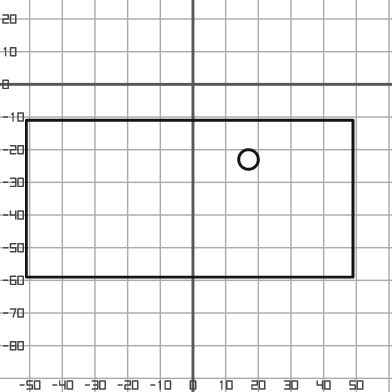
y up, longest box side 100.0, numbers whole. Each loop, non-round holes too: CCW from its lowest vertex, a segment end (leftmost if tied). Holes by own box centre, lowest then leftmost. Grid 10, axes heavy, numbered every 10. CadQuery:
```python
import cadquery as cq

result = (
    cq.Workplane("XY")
    .moveTo(-51.0, -59.0)
    .lineTo(49.0, -59.0)
    .lineTo(49.0, -11.0)
    .lineTo(-51.0, -11.0)
    .close()
    .moveTo(17.0, -23.0)
    .circle(3.0)
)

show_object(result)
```